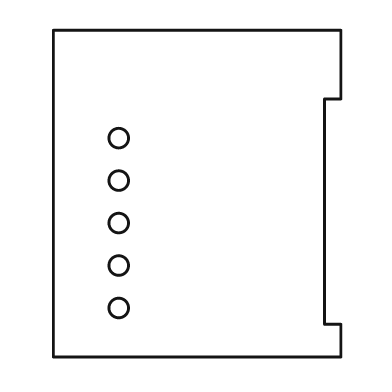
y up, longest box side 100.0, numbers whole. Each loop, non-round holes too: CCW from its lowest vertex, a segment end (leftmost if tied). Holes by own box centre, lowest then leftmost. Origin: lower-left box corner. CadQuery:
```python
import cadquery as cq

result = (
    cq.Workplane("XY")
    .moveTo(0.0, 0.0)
    .lineTo(88.0, 0.0)
    .lineTo(88.0, 10.0)
    .lineTo(83.0, 10.0)
    .lineTo(83.0, 79.0)
    .lineTo(88.0, 79.0)
    .lineTo(88.0, 100.0)
    .lineTo(0.0, 100.0)
    .close()
    .moveTo(20.0, 15.0)
    .circle(3.0)
    .moveTo(20.0, 28.0)
    .circle(3.0)
    .moveTo(20.0, 41.0)
    .circle(3.0)
    .moveTo(20.0, 54.0)
    .circle(3.0)
    .moveTo(20.0, 67.0)
    .circle(3.0)
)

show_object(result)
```